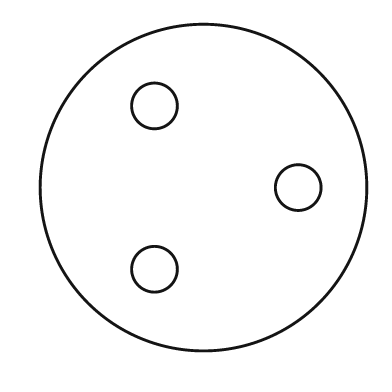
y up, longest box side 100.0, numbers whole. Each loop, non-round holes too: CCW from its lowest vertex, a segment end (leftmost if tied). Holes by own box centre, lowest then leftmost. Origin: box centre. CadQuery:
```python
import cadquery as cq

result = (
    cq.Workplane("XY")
    .moveTo(0.0, 0.0)
    .circle(50.0)
    .moveTo(-15.0, -25.0)
    .circle(7.0)
    .moveTo(29.0, 0.0)
    .circle(7.0)
    .moveTo(-15.0, 25.0)
    .circle(7.0)
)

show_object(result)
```